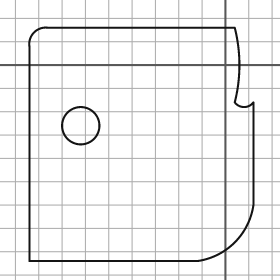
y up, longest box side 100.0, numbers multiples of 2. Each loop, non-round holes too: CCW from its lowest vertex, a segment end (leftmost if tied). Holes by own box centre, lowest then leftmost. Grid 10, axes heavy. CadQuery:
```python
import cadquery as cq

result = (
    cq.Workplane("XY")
    .moveTo(-84.0, -84.0)
    .lineTo(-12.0, -84.0)
    .threePointArc((4.0, -76.0), (12.0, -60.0))
    .lineTo(12.0, -16.0)
    .threePointArc((8.0, -18.0), (4.0, -16.0))
    .threePointArc((6.0, 0.0), (4.0, 16.0))
    .lineTo(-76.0, 16.0)
    .threePointArc((-82.0, 14.0), (-84.0, 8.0))
    .close()
    .moveTo(-62.0, -26.0)
    .circle(8.0)
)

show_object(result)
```